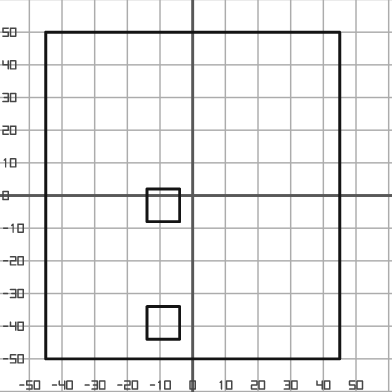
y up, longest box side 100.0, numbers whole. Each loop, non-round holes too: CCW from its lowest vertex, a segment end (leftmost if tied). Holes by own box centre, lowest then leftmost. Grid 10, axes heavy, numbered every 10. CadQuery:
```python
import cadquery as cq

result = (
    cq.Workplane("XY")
    .moveTo(-45.0, -50.0)
    .lineTo(45.0, -50.0)
    .lineTo(45.0, 50.0)
    .lineTo(-45.0, 50.0)
    .close()
    .moveTo(-14.0, -44.0)
    .lineTo(-4.0, -44.0)
    .lineTo(-4.0, -34.0)
    .lineTo(-14.0, -34.0)
    .close()
    .moveTo(-14.0, -8.0)
    .lineTo(-4.0, -8.0)
    .lineTo(-4.0, 2.0)
    .lineTo(-14.0, 2.0)
    .close()
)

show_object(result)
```